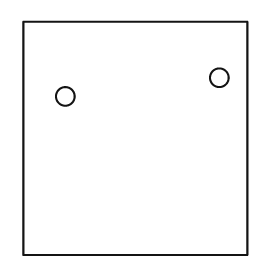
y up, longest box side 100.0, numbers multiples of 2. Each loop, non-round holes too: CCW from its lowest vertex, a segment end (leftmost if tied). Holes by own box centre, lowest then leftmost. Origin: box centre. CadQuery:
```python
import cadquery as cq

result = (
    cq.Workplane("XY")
    .moveTo(-48.0, -50.0)
    .lineTo(48.0, -50.0)
    .lineTo(48.0, 50.0)
    .lineTo(-48.0, 50.0)
    .close()
    .moveTo(-30.0, 18.0)
    .circle(4.0)
    .moveTo(36.0, 26.0)
    .circle(4.0)
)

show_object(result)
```